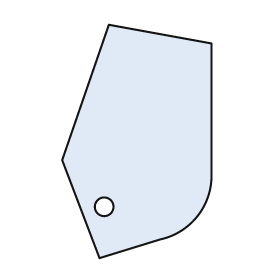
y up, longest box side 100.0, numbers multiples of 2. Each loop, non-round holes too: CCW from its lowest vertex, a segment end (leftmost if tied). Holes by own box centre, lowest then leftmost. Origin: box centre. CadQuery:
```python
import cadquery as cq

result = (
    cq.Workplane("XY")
    .moveTo(-16.0, -50.0)
    .lineTo(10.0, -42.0)
    .threePointArc((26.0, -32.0), (32.0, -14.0))
    .lineTo(32.0, 42.0)
    .lineTo(-12.0, 50.0)
    .lineTo(-32.0, -8.0)
    .close()
    .moveTo(-14.0, -28.0)
    .circle(4.0)
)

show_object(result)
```